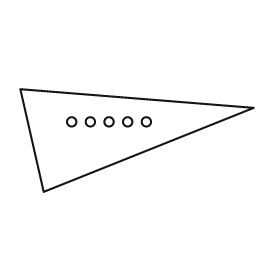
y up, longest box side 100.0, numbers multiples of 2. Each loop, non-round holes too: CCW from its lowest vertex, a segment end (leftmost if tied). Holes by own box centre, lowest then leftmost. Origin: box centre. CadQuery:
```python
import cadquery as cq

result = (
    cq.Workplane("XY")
    .moveTo(-40.0, -22.0)
    .lineTo(50.0, 14.0)
    .lineTo(-50.0, 22.0)
    .close()
    .moveTo(-28.0, 8.0)
    .circle(2.0)
    .moveTo(-20.0, 8.0)
    .circle(2.0)
    .moveTo(-12.0, 8.0)
    .circle(2.0)
    .moveTo(-4.0, 8.0)
    .circle(2.0)
    .moveTo(4.0, 8.0)
    .circle(2.0)
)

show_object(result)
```